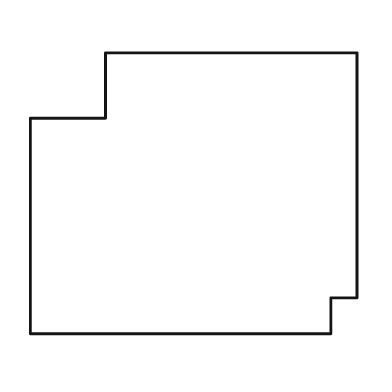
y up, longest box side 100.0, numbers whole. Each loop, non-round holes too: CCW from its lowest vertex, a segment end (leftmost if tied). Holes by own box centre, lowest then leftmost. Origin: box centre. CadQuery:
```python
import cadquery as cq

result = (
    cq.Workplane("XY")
    .moveTo(-50.0, -43.0)
    .lineTo(42.0, -43.0)
    .lineTo(42.0, -32.0)
    .lineTo(50.0, -32.0)
    .lineTo(50.0, 43.0)
    .lineTo(-27.0, 43.0)
    .lineTo(-27.0, 23.0)
    .lineTo(-50.0, 23.0)
    .close()
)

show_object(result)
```